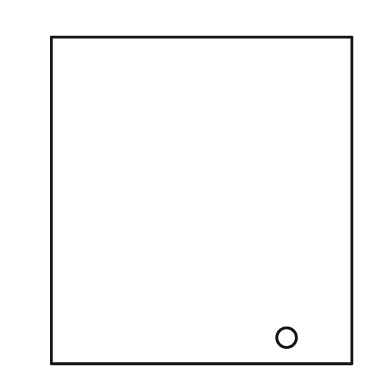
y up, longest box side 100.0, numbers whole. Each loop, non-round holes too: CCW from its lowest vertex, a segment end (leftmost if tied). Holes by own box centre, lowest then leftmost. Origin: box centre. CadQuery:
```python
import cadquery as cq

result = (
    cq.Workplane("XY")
    .moveTo(-46.0, -50.0)
    .lineTo(46.0, -50.0)
    .lineTo(46.0, 50.0)
    .lineTo(-46.0, 50.0)
    .close()
    .moveTo(26.0, -42.0)
    .circle(3.0)
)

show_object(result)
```